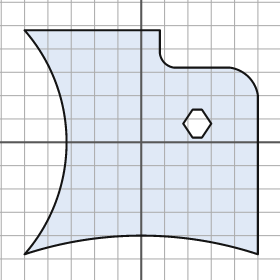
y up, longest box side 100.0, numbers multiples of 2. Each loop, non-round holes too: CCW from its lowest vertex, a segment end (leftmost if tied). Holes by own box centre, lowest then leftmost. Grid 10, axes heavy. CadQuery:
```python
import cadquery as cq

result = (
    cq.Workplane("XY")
    .moveTo(-50.0, -48.0)
    .threePointArc((0.0, -40.0), (50.0, -48.0))
    .lineTo(50.0, 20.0)
    .threePointArc((46.0, 28.0), (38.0, 32.0))
    .lineTo(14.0, 32.0)
    .threePointArc((10.0, 34.0), (8.0, 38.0))
    .lineTo(8.0, 48.0)
    .lineTo(-50.0, 48.0)
    .threePointArc((-32.0, 0.0), (-50.0, -48.0))
    .close()
    .moveTo(22.0, 2.0)
    .lineTo(26.0, 2.0)
    .lineTo(30.0, 8.0)
    .lineTo(26.0, 14.0)
    .lineTo(22.0, 14.0)
    .lineTo(18.0, 8.0)
    .close()
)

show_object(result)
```